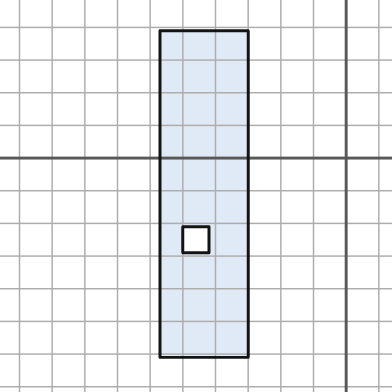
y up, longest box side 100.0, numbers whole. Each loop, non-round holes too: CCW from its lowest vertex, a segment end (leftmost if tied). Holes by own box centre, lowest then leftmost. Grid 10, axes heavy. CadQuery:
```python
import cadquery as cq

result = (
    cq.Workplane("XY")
    .moveTo(-57.0, -61.0)
    .lineTo(-30.0, -61.0)
    .lineTo(-30.0, 39.0)
    .lineTo(-57.0, 39.0)
    .close()
    .moveTo(-50.0, -29.0)
    .lineTo(-42.0, -29.0)
    .lineTo(-42.0, -21.0)
    .lineTo(-50.0, -21.0)
    .close()
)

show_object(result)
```